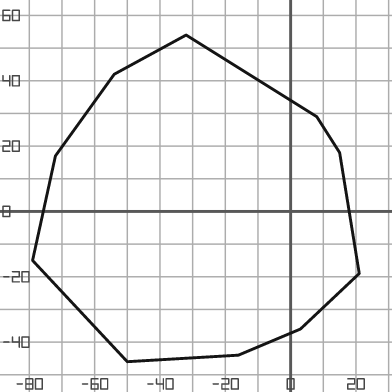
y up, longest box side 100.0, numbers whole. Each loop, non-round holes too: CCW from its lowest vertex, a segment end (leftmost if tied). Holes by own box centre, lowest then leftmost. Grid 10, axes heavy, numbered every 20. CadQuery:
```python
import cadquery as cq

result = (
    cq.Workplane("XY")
    .moveTo(-50.0, -46.0)
    .lineTo(-16.0, -44.0)
    .lineTo(3.0, -36.0)
    .lineTo(21.0, -19.0)
    .lineTo(15.0, 18.0)
    .lineTo(8.0, 29.0)
    .lineTo(-32.0, 54.0)
    .lineTo(-54.0, 42.0)
    .lineTo(-72.0, 17.0)
    .lineTo(-79.0, -15.0)
    .close()
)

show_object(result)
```